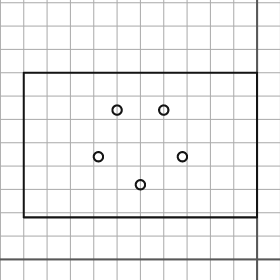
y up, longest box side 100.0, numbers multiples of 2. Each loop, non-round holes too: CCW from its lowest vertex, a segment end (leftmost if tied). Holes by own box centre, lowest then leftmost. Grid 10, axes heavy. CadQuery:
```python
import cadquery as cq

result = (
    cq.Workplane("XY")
    .moveTo(-100.0, 18.0)
    .lineTo(0.0, 18.0)
    .lineTo(0.0, 80.0)
    .lineTo(-100.0, 80.0)
    .close()
    .moveTo(-50.0, 32.0)
    .circle(2.0)
    .moveTo(-68.0, 44.0)
    .circle(2.0)
    .moveTo(-32.0, 44.0)
    .circle(2.0)
    .moveTo(-60.0, 64.0)
    .circle(2.0)
    .moveTo(-40.0, 64.0)
    .circle(2.0)
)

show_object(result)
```